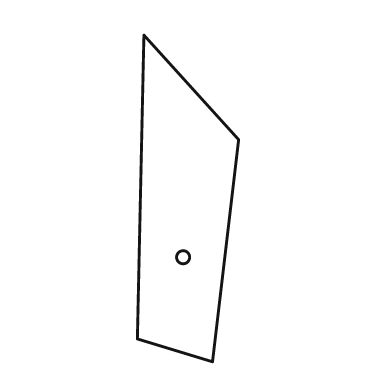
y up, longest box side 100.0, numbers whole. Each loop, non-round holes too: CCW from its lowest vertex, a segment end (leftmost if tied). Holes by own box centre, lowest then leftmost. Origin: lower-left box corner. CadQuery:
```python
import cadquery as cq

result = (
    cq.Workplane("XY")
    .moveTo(23.0, 0.0)
    .lineTo(31.0, 68.0)
    .lineTo(2.0, 100.0)
    .lineTo(0.0, 7.0)
    .close()
    .moveTo(14.0, 32.0)
    .circle(2.0)
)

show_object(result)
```